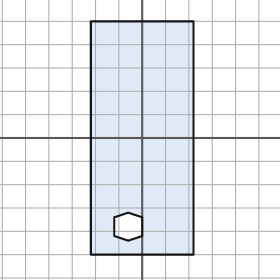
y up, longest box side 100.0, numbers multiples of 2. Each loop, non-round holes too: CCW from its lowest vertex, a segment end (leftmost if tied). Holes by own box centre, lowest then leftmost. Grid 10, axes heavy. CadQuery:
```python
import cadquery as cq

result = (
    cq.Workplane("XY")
    .moveTo(-22.0, -50.0)
    .lineTo(22.0, -50.0)
    .lineTo(22.0, 50.0)
    .lineTo(-22.0, 50.0)
    .close()
    .moveTo(-6.0, -44.0)
    .lineTo(0.0, -42.0)
    .lineTo(0.0, -34.0)
    .lineTo(-6.0, -32.0)
    .lineTo(-12.0, -34.0)
    .lineTo(-12.0, -42.0)
    .close()
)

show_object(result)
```